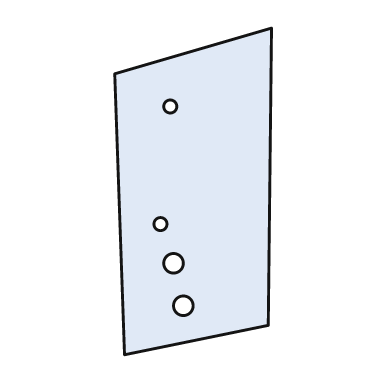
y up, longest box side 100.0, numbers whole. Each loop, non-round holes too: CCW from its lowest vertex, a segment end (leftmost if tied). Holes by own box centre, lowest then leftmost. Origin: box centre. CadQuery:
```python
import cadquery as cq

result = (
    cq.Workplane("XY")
    .moveTo(-21.0, -50.0)
    .lineTo(23.0, -41.0)
    .lineTo(24.0, 50.0)
    .lineTo(-24.0, 36.0)
    .close()
    .moveTo(-3.0, -35.0)
    .circle(3.0)
    .moveTo(-6.0, -22.0)
    .circle(3.0)
    .moveTo(-10.0, -10.0)
    .circle(2.0)
    .moveTo(-7.0, 26.0)
    .circle(2.0)
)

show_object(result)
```